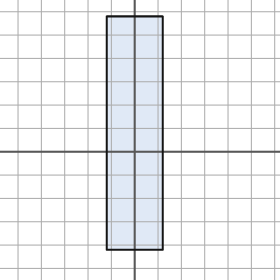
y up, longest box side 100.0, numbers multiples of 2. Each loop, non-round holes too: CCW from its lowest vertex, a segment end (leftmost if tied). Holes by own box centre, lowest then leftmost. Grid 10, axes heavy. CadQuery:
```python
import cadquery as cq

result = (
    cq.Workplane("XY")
    .moveTo(-12.0, -42.0)
    .lineTo(12.0, -42.0)
    .lineTo(12.0, 58.0)
    .lineTo(-12.0, 58.0)
    .close()
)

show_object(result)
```